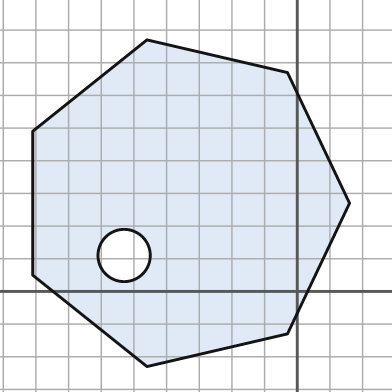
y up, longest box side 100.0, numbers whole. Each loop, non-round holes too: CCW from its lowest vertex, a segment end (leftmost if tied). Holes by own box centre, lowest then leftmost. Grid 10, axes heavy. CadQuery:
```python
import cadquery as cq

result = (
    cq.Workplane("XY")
    .moveTo(-46.0, -23.0)
    .lineTo(-3.0, -13.0)
    .lineTo(16.0, 27.0)
    .lineTo(-3.0, 67.0)
    .lineTo(-46.0, 77.0)
    .lineTo(-81.0, 49.0)
    .lineTo(-81.0, 5.0)
    .close()
    .moveTo(-53.0, 11.0)
    .circle(8.0)
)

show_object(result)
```